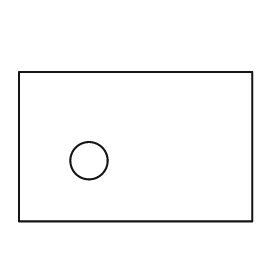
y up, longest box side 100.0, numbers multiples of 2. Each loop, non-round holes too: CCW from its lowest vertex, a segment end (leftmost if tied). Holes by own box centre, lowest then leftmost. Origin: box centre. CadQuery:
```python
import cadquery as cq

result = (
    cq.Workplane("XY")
    .moveTo(-50.0, -32.0)
    .lineTo(50.0, -32.0)
    .lineTo(50.0, 32.0)
    .lineTo(-50.0, 32.0)
    .close()
    .moveTo(-20.0, -6.0)
    .circle(8.0)
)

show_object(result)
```